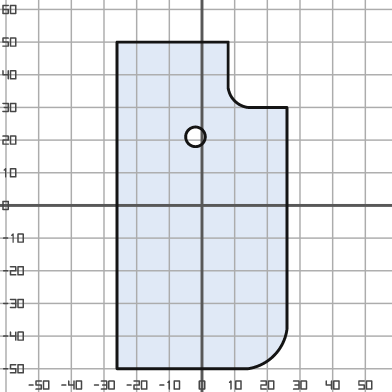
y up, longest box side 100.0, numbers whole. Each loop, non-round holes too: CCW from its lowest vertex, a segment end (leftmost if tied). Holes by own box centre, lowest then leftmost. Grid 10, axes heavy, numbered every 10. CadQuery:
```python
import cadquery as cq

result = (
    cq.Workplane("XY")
    .moveTo(-26.0, -50.0)
    .lineTo(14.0, -50.0)
    .threePointArc((22.0, -46.0), (26.0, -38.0))
    .lineTo(26.0, 30.0)
    .lineTo(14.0, 30.0)
    .threePointArc((10.0, 32.0), (8.0, 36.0))
    .lineTo(8.0, 50.0)
    .lineTo(-26.0, 50.0)
    .close()
    .moveTo(-2.0, 21.0)
    .circle(3.0)
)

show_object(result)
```